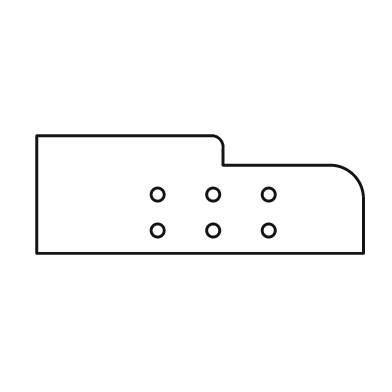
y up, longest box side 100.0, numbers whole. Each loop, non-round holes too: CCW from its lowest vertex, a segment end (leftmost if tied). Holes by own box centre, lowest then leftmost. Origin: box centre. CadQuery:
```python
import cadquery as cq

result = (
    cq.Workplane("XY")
    .moveTo(-50.0, -18.0)
    .lineTo(50.0, -18.0)
    .lineTo(50.0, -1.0)
    .threePointArc((47.0, 6.0), (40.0, 9.0))
    .lineTo(7.0, 9.0)
    .lineTo(7.0, 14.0)
    .threePointArc((6.0, 17.0), (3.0, 18.0))
    .lineTo(-50.0, 18.0)
    .close()
    .moveTo(-13.0, -11.0)
    .circle(2.0)
    .moveTo(4.0, -11.0)
    .circle(2.0)
    .moveTo(21.0, -11.0)
    .circle(2.0)
    .moveTo(-13.0, 0.0)
    .circle(2.0)
    .moveTo(4.0, 0.0)
    .circle(2.0)
    .moveTo(21.0, 0.0)
    .circle(2.0)
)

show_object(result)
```